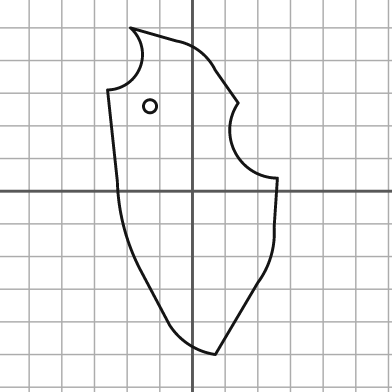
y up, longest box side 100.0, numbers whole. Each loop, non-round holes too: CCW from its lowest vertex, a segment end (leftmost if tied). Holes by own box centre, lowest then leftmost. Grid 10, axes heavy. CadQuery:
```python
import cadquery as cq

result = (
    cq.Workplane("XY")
    .moveTo(7.0, -50.0)
    .lineTo(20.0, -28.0)
    .threePointArc((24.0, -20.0), (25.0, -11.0))
    .lineTo(26.0, 4.0)
    .threePointArc((13.0, 12.0), (14.0, 27.0))
    .lineTo(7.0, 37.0)
    .threePointArc((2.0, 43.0), (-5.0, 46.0))
    .lineTo(-19.0, 50.0)
    .threePointArc((-16.0, 38.0), (-26.0, 31.0))
    .lineTo(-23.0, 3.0)
    .threePointArc((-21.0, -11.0), (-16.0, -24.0))
    .lineTo(-7.0, -41.0)
    .threePointArc((-1.0, -47.0), (7.0, -50.0))
    .close()
    .moveTo(-13.0, 26.0)
    .circle(2.0)
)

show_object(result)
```